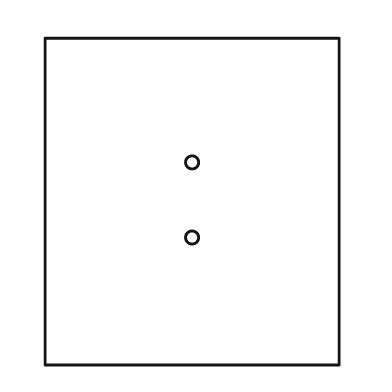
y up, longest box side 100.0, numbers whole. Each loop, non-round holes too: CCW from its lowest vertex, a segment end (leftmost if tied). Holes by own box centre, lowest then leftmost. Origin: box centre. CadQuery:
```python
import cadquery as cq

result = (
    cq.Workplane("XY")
    .moveTo(-45.0, -50.0)
    .lineTo(45.0, -50.0)
    .lineTo(45.0, 50.0)
    .lineTo(-45.0, 50.0)
    .close()
    .moveTo(0.0, -11.0)
    .circle(2.0)
    .moveTo(0.0, 12.0)
    .circle(2.0)
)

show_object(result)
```